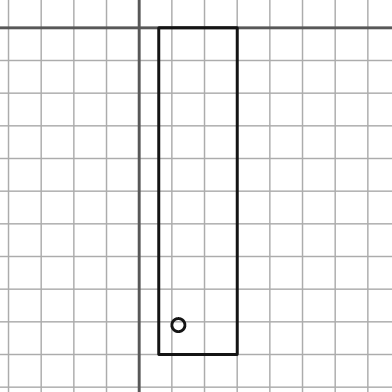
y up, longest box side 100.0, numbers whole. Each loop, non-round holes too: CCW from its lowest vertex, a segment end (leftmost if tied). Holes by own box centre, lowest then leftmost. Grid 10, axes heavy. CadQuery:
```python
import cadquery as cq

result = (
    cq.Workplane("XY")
    .moveTo(6.0, -100.0)
    .lineTo(30.0, -100.0)
    .lineTo(30.0, 0.0)
    .lineTo(6.0, 0.0)
    .close()
    .moveTo(12.0, -91.0)
    .circle(2.0)
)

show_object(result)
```